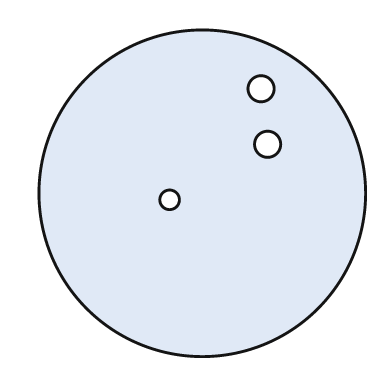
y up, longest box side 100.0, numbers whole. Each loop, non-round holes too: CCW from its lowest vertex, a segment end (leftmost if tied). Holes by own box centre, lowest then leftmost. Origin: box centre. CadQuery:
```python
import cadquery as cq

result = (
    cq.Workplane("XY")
    .moveTo(0.0, 0.0)
    .circle(50.0)
    .moveTo(-10.0, -2.0)
    .circle(3.0)
    .moveTo(20.0, 15.0)
    .circle(4.0)
    .moveTo(18.0, 32.0)
    .circle(4.0)
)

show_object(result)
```